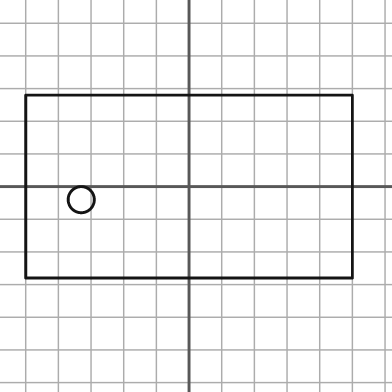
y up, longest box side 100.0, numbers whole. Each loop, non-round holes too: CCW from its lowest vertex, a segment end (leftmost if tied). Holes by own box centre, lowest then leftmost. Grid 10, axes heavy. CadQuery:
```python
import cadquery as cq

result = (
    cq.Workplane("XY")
    .moveTo(-50.0, -28.0)
    .lineTo(50.0, -28.0)
    .lineTo(50.0, 28.0)
    .lineTo(-50.0, 28.0)
    .close()
    .moveTo(-33.0, -4.0)
    .circle(4.0)
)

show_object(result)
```